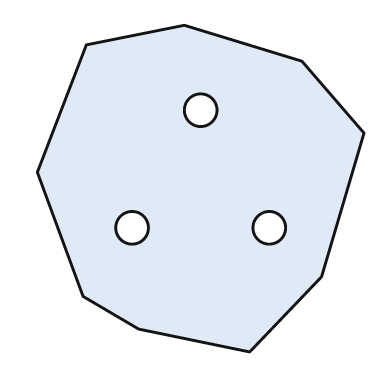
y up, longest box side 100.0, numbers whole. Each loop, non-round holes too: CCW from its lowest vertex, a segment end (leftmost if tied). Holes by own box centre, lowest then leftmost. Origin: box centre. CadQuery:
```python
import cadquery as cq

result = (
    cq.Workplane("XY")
    .moveTo(15.0, -50.0)
    .lineTo(37.0, -27.0)
    .lineTo(50.0, 17.0)
    .lineTo(31.0, 39.0)
    .lineTo(-5.0, 50.0)
    .lineTo(-35.0, 44.0)
    .lineTo(-50.0, 5.0)
    .lineTo(-36.0, -33.0)
    .lineTo(-19.0, -43.0)
    .close()
    .moveTo(-21.0, -12.0)
    .circle(5.0)
    .moveTo(21.0, -12.0)
    .circle(5.0)
    .moveTo(0.0, 24.0)
    .circle(5.0)
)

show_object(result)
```